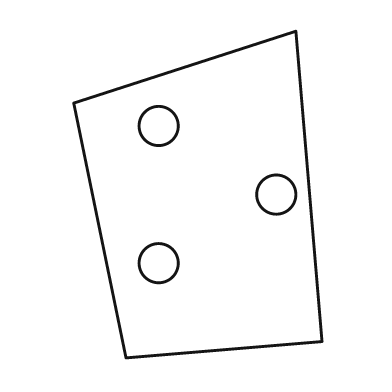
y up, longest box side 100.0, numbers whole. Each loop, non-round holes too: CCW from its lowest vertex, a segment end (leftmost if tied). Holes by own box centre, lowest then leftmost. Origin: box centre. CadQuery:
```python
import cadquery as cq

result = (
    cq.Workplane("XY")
    .moveTo(-22.0, -50.0)
    .lineTo(38.0, -45.0)
    .lineTo(30.0, 50.0)
    .lineTo(-38.0, 28.0)
    .close()
    .moveTo(-12.0, -21.0)
    .circle(6.0)
    .moveTo(24.0, 0.0)
    .circle(6.0)
    .moveTo(-12.0, 21.0)
    .circle(6.0)
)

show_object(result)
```